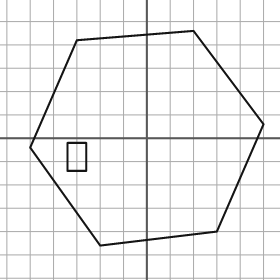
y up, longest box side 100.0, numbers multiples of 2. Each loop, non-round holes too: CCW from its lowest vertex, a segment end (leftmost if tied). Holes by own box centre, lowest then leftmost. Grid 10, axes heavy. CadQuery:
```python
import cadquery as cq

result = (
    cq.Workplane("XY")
    .moveTo(-20.0, -46.0)
    .lineTo(30.0, -40.0)
    .lineTo(50.0, 6.0)
    .lineTo(20.0, 46.0)
    .lineTo(-30.0, 42.0)
    .lineTo(-50.0, -4.0)
    .close()
    .moveTo(-34.0, -14.0)
    .lineTo(-26.0, -14.0)
    .lineTo(-26.0, -2.0)
    .lineTo(-34.0, -2.0)
    .close()
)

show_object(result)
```